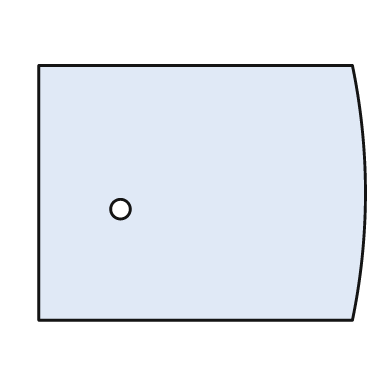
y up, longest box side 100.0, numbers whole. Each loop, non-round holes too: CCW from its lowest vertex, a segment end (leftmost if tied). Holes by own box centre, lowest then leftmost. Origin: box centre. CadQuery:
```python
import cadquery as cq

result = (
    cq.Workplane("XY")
    .moveTo(-50.0, -39.0)
    .lineTo(46.0, -39.0)
    .threePointArc((50.0, 0.0), (46.0, 39.0))
    .lineTo(-50.0, 39.0)
    .close()
    .moveTo(-25.0, -5.0)
    .circle(3.0)
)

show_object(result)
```